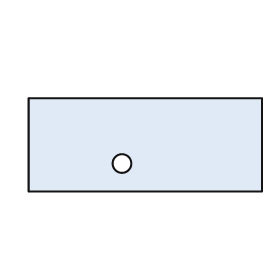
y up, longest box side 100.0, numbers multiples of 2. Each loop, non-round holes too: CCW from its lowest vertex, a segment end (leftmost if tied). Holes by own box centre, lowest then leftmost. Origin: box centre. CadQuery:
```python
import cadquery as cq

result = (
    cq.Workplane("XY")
    .moveTo(-50.0, -20.0)
    .lineTo(50.0, -20.0)
    .lineTo(50.0, 20.0)
    .lineTo(-50.0, 20.0)
    .close()
    .moveTo(-10.0, -8.0)
    .circle(4.0)
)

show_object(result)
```